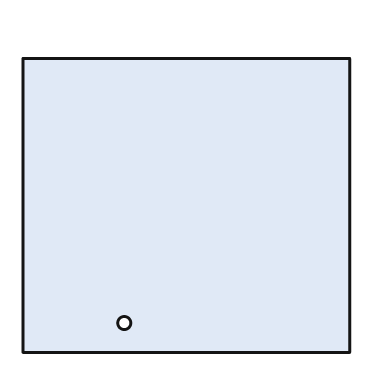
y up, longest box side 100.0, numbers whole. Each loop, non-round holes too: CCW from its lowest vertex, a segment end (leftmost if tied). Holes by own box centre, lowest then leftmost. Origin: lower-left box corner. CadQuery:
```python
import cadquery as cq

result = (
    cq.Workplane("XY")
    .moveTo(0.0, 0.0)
    .lineTo(100.0, 0.0)
    .lineTo(100.0, 90.0)
    .lineTo(0.0, 90.0)
    .close()
    .moveTo(31.0, 9.0)
    .circle(2.0)
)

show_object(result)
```